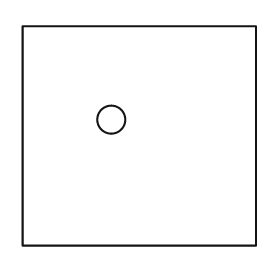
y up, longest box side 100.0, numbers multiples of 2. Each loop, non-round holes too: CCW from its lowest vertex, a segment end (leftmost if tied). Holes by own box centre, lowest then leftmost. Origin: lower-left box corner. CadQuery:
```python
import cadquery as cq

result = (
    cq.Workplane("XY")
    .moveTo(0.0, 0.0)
    .lineTo(100.0, 0.0)
    .lineTo(100.0, 94.0)
    .lineTo(0.0, 94.0)
    .close()
    .moveTo(38.0, 54.0)
    .circle(6.0)
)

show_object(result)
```